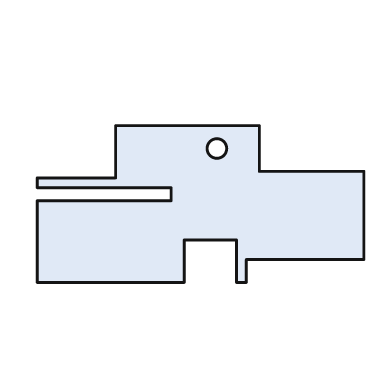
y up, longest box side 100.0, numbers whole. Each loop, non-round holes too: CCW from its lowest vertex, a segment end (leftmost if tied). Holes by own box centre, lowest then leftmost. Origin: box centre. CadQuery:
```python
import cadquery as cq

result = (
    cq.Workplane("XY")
    .moveTo(-50.0, -24.0)
    .lineTo(-5.0, -24.0)
    .lineTo(-5.0, -11.0)
    .lineTo(11.0, -11.0)
    .lineTo(11.0, -24.0)
    .lineTo(14.0, -24.0)
    .lineTo(14.0, -17.0)
    .lineTo(50.0, -17.0)
    .lineTo(50.0, 10.0)
    .lineTo(18.0, 10.0)
    .lineTo(18.0, 24.0)
    .lineTo(-26.0, 24.0)
    .lineTo(-26.0, 8.0)
    .lineTo(-50.0, 8.0)
    .lineTo(-50.0, 5.0)
    .lineTo(-9.0, 5.0)
    .lineTo(-9.0, 1.0)
    .lineTo(-50.0, 1.0)
    .close()
    .moveTo(5.0, 17.0)
    .circle(3.0)
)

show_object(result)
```